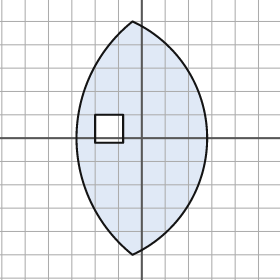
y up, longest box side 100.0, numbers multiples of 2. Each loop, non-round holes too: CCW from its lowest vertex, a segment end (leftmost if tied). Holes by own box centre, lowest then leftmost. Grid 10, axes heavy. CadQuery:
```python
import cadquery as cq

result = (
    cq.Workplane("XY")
    .moveTo(-4.0, -50.0)
    .threePointArc((28.0, 0.0), (-4.0, 50.0))
    .threePointArc((-28.0, 0.0), (-4.0, -50.0))
    .close()
    .moveTo(-20.0, -2.0)
    .lineTo(-8.0, -2.0)
    .lineTo(-8.0, 10.0)
    .lineTo(-20.0, 10.0)
    .close()
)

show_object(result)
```